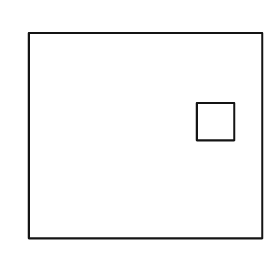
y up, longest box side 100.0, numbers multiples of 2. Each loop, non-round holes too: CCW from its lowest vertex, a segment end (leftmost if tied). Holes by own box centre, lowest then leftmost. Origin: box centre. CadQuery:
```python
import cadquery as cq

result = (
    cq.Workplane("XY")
    .moveTo(-50.0, -44.0)
    .lineTo(50.0, -44.0)
    .lineTo(50.0, 44.0)
    .lineTo(-50.0, 44.0)
    .close()
    .moveTo(22.0, -2.0)
    .lineTo(38.0, -2.0)
    .lineTo(38.0, 14.0)
    .lineTo(22.0, 14.0)
    .close()
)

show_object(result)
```